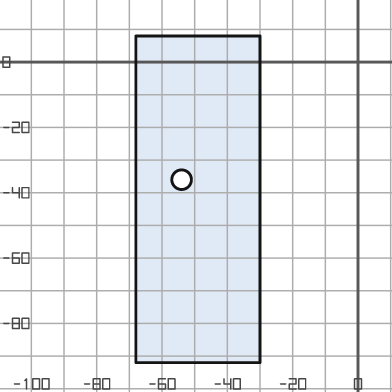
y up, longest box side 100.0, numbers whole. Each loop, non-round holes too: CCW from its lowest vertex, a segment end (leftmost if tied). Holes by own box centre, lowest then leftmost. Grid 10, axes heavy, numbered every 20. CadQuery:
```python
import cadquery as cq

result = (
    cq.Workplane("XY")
    .moveTo(-68.0, -92.0)
    .lineTo(-30.0, -92.0)
    .lineTo(-30.0, 8.0)
    .lineTo(-68.0, 8.0)
    .close()
    .moveTo(-54.0, -36.0)
    .circle(3.0)
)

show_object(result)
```